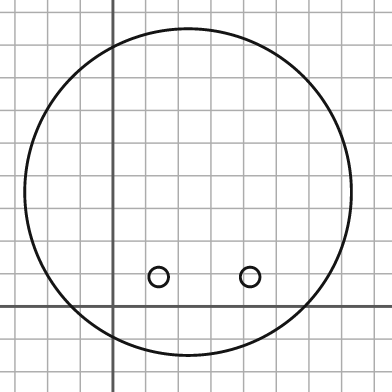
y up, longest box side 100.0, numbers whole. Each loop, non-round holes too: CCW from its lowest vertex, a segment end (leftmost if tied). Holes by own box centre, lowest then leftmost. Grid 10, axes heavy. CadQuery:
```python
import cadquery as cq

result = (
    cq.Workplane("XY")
    .moveTo(23.0, 35.0)
    .circle(50.0)
    .moveTo(14.0, 9.0)
    .circle(3.0)
    .moveTo(42.0, 9.0)
    .circle(3.0)
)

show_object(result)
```